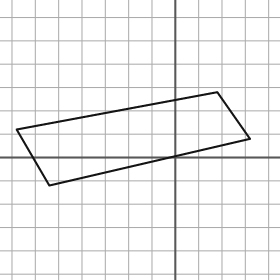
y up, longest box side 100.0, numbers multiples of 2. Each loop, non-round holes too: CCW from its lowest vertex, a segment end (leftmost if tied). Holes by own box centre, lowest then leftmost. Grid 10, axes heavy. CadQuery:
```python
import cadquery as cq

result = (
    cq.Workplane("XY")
    .moveTo(-54.0, -12.0)
    .lineTo(32.0, 8.0)
    .lineTo(18.0, 28.0)
    .lineTo(-68.0, 12.0)
    .close()
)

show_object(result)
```